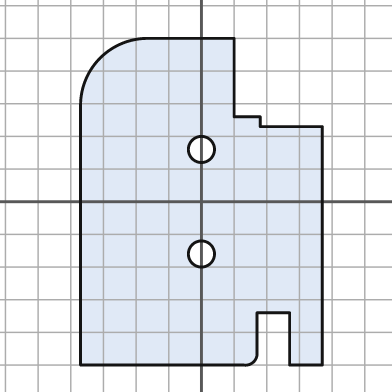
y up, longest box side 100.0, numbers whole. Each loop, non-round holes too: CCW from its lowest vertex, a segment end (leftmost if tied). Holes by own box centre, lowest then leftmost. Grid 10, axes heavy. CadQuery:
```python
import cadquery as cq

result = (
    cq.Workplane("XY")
    .moveTo(-37.0, -50.0)
    .lineTo(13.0, -50.0)
    .threePointArc((16.0, -49.0), (17.0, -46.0))
    .lineTo(17.0, -34.0)
    .lineTo(27.0, -34.0)
    .lineTo(27.0, -50.0)
    .lineTo(37.0, -50.0)
    .lineTo(37.0, 23.0)
    .lineTo(18.0, 23.0)
    .lineTo(18.0, 26.0)
    .lineTo(10.0, 26.0)
    .lineTo(10.0, 50.0)
    .lineTo(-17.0, 50.0)
    .threePointArc((-31.0, 44.0), (-37.0, 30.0))
    .close()
    .moveTo(0.0, -16.0)
    .circle(4.0)
    .moveTo(0.0, 16.0)
    .circle(4.0)
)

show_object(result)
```